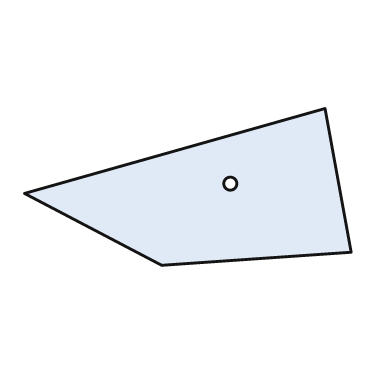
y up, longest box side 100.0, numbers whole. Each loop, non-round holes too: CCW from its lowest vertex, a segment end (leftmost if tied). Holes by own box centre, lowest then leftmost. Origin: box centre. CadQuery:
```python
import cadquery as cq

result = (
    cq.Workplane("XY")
    .moveTo(-8.0, -24.0)
    .lineTo(50.0, -20.0)
    .lineTo(42.0, 24.0)
    .lineTo(-50.0, -2.0)
    .close()
    .moveTo(13.0, 1.0)
    .circle(2.0)
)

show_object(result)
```